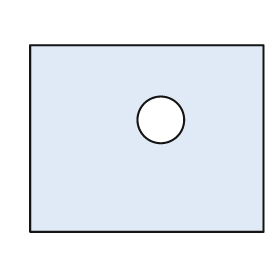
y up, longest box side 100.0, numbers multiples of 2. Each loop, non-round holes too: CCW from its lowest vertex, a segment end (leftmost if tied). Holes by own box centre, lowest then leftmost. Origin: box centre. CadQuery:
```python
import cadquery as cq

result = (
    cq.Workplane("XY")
    .moveTo(-50.0, -40.0)
    .lineTo(50.0, -40.0)
    .lineTo(50.0, 40.0)
    .lineTo(-50.0, 40.0)
    .close()
    .moveTo(6.0, 8.0)
    .circle(10.0)
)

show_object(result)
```